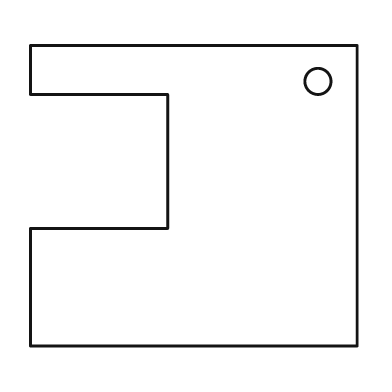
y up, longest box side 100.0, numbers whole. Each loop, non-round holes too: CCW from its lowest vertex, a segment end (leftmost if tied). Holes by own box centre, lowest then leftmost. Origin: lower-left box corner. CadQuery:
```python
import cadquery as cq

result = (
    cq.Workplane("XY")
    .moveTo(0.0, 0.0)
    .lineTo(100.0, 0.0)
    .lineTo(100.0, 92.0)
    .lineTo(0.0, 92.0)
    .lineTo(0.0, 77.0)
    .lineTo(42.0, 77.0)
    .lineTo(42.0, 36.0)
    .lineTo(0.0, 36.0)
    .close()
    .moveTo(88.0, 81.0)
    .circle(4.0)
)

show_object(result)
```